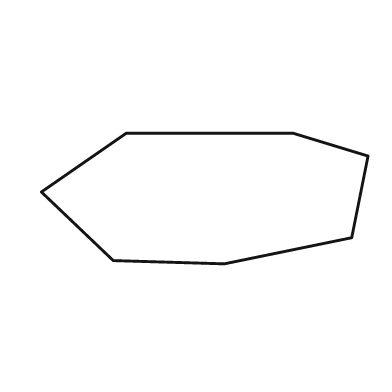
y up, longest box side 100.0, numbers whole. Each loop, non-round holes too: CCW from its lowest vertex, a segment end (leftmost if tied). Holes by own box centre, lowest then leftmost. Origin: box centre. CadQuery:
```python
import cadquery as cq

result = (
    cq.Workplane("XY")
    .moveTo(6.0, -20.0)
    .lineTo(45.0, -12.0)
    .lineTo(50.0, 13.0)
    .lineTo(27.0, 20.0)
    .lineTo(-24.0, 20.0)
    .lineTo(-50.0, 2.0)
    .lineTo(-28.0, -19.0)
    .close()
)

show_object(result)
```